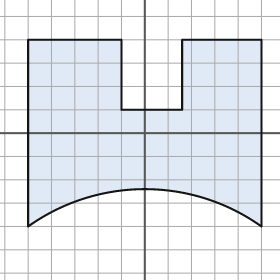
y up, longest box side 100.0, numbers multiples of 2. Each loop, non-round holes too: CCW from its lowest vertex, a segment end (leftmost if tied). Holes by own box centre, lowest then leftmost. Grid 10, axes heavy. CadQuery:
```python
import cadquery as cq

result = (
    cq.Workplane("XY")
    .moveTo(-50.0, -40.0)
    .threePointArc((0.0, -24.0), (50.0, -40.0))
    .lineTo(50.0, 40.0)
    .lineTo(16.0, 40.0)
    .lineTo(16.0, 10.0)
    .lineTo(-10.0, 10.0)
    .lineTo(-10.0, 40.0)
    .lineTo(-50.0, 40.0)
    .close()
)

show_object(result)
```